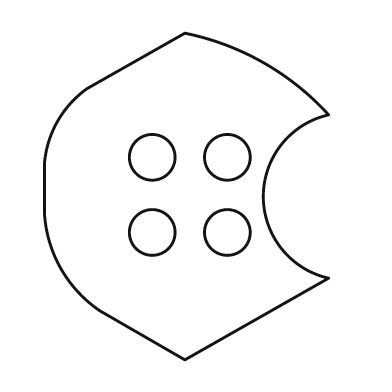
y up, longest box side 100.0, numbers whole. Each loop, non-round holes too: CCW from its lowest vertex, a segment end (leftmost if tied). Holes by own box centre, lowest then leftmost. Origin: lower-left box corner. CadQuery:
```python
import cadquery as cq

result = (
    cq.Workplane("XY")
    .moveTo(43.0, 0.0)
    .lineTo(87.0, 25.0)
    .threePointArc((67.0, 50.0), (87.0, 75.0))
    .threePointArc((67.0, 91.0), (43.0, 100.0))
    .lineTo(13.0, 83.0)
    .threePointArc((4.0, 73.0), (0.0, 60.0))
    .lineTo(0.0, 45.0)
    .threePointArc((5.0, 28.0), (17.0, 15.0))
    .close()
    .moveTo(33.0, 39.0)
    .circle(7.0)
    .moveTo(56.0, 39.0)
    .circle(7.0)
    .moveTo(33.0, 62.0)
    .circle(7.0)
    .moveTo(56.0, 62.0)
    .circle(7.0)
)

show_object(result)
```